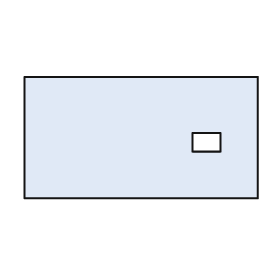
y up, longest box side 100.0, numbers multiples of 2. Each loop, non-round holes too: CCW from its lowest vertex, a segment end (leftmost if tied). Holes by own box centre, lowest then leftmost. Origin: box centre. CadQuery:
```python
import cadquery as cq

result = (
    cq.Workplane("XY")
    .moveTo(-50.0, -26.0)
    .lineTo(50.0, -26.0)
    .lineTo(50.0, 26.0)
    .lineTo(-50.0, 26.0)
    .close()
    .moveTo(22.0, -6.0)
    .lineTo(34.0, -6.0)
    .lineTo(34.0, 2.0)
    .lineTo(22.0, 2.0)
    .close()
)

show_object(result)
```